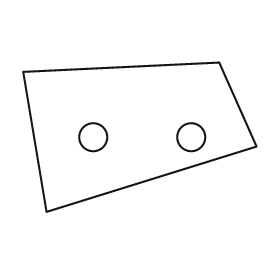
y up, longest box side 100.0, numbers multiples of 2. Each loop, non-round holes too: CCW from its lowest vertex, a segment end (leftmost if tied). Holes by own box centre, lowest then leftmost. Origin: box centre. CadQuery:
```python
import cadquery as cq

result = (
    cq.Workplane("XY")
    .moveTo(-40.0, -32.0)
    .lineTo(50.0, -4.0)
    .lineTo(34.0, 32.0)
    .lineTo(-50.0, 28.0)
    .close()
    .moveTo(-20.0, 0.0)
    .circle(6.0)
    .moveTo(22.0, 0.0)
    .circle(6.0)
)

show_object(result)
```